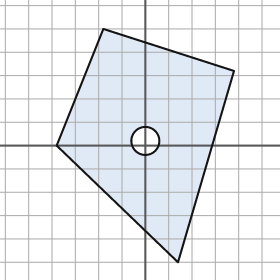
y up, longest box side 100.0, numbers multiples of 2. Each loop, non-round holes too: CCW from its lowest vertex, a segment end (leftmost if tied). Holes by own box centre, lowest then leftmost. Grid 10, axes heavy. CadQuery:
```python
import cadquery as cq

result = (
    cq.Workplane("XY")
    .moveTo(14.0, -50.0)
    .lineTo(38.0, 32.0)
    .lineTo(-18.0, 50.0)
    .lineTo(-38.0, 0.0)
    .close()
    .moveTo(0.0, 2.0)
    .circle(6.0)
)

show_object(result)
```